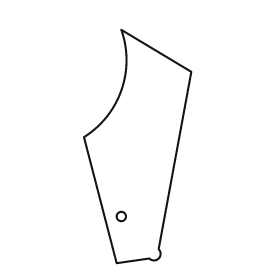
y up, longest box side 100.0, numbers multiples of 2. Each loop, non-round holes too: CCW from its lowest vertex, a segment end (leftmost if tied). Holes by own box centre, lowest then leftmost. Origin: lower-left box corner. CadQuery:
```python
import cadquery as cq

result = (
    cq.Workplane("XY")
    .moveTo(14.0, 0.0)
    .lineTo(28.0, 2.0)
    .threePointArc((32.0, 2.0), (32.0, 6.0))
    .lineTo(46.0, 82.0)
    .lineTo(16.0, 100.0)
    .threePointArc((16.0, 74.0), (0.0, 54.0))
    .close()
    .moveTo(16.0, 20.0)
    .circle(2.0)
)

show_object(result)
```